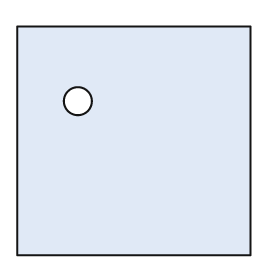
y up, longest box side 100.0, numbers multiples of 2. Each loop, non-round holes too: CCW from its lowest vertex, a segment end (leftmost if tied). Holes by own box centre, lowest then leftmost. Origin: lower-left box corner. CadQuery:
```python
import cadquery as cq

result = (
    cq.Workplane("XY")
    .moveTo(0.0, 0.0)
    .lineTo(100.0, 0.0)
    .lineTo(100.0, 98.0)
    .lineTo(0.0, 98.0)
    .close()
    .moveTo(26.0, 66.0)
    .circle(6.0)
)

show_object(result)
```